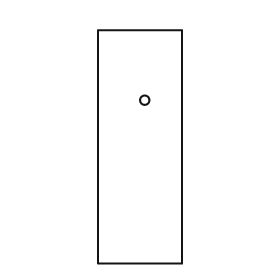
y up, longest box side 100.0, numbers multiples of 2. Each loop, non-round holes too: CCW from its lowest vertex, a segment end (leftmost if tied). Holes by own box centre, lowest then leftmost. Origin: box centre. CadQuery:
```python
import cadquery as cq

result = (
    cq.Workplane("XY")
    .moveTo(-18.0, -50.0)
    .lineTo(18.0, -50.0)
    .lineTo(18.0, 50.0)
    .lineTo(-18.0, 50.0)
    .close()
    .moveTo(2.0, 20.0)
    .circle(2.0)
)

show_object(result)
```